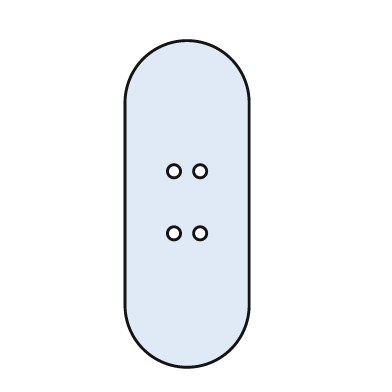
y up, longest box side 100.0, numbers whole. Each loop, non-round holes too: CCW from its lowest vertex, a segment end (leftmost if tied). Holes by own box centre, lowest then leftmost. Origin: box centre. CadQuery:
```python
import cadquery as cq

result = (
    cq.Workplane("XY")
    .moveTo(-19.0, -31.0)
    .threePointArc((0.0, -50.0), (19.0, -31.0))
    .lineTo(19.0, 31.0)
    .threePointArc((0.0, 50.0), (-19.0, 31.0))
    .close()
    .moveTo(-4.0, -9.0)
    .circle(2.0)
    .moveTo(4.0, -9.0)
    .circle(2.0)
    .moveTo(-4.0, 10.0)
    .circle(2.0)
    .moveTo(4.0, 10.0)
    .circle(2.0)
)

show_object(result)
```